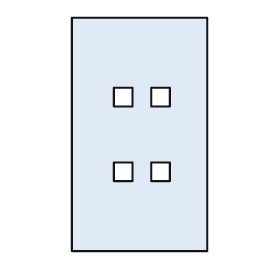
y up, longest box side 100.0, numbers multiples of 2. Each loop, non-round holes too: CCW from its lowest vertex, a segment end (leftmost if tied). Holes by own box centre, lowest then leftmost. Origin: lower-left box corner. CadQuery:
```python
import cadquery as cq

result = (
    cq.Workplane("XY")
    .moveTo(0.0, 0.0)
    .lineTo(58.0, 0.0)
    .lineTo(58.0, 100.0)
    .lineTo(0.0, 100.0)
    .close()
    .moveTo(18.0, 30.0)
    .lineTo(26.0, 30.0)
    .lineTo(26.0, 38.0)
    .lineTo(18.0, 38.0)
    .close()
    .moveTo(34.0, 30.0)
    .lineTo(42.0, 30.0)
    .lineTo(42.0, 38.0)
    .lineTo(34.0, 38.0)
    .close()
    .moveTo(18.0, 62.0)
    .lineTo(26.0, 62.0)
    .lineTo(26.0, 70.0)
    .lineTo(18.0, 70.0)
    .close()
    .moveTo(34.0, 62.0)
    .lineTo(42.0, 62.0)
    .lineTo(42.0, 70.0)
    .lineTo(34.0, 70.0)
    .close()
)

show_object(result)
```